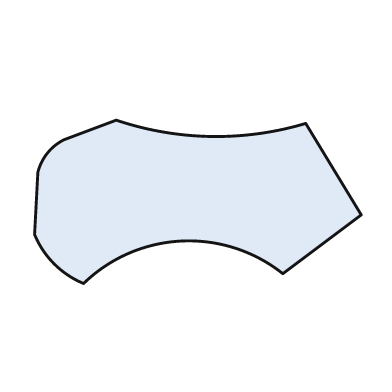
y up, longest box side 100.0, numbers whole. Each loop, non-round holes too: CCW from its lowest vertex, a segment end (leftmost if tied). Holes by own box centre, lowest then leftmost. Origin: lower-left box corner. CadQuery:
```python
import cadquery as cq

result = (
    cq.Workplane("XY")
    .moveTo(15.0, 0.0)
    .threePointArc((45.0, 13.0), (76.0, 3.0))
    .lineTo(100.0, 21.0)
    .lineTo(83.0, 49.0)
    .threePointArc((54.0, 45.0), (25.0, 50.0))
    .lineTo(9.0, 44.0)
    .threePointArc((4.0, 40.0), (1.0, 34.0))
    .lineTo(0.0, 15.0)
    .threePointArc((6.0, 6.0), (15.0, 0.0))
    .close()
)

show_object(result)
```